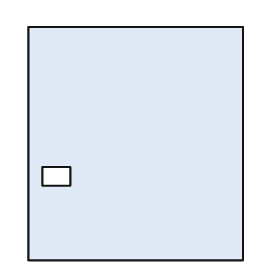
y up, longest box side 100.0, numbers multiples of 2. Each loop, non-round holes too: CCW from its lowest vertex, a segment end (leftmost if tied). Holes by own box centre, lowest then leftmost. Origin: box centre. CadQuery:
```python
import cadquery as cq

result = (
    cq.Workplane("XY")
    .moveTo(-46.0, -50.0)
    .lineTo(46.0, -50.0)
    .lineTo(46.0, 50.0)
    .lineTo(-46.0, 50.0)
    .close()
    .moveTo(-40.0, -18.0)
    .lineTo(-28.0, -18.0)
    .lineTo(-28.0, -10.0)
    .lineTo(-40.0, -10.0)
    .close()
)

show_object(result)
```